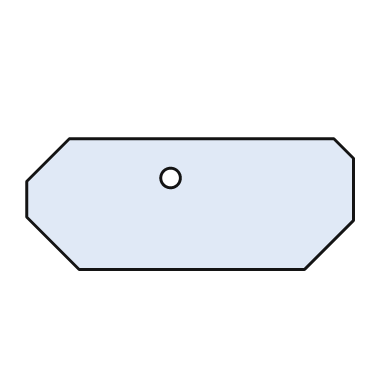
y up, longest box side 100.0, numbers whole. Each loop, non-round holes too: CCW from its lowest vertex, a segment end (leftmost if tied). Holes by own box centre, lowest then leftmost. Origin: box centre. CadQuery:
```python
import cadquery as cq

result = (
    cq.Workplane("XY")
    .moveTo(-34.0, -20.0)
    .lineTo(35.0, -20.0)
    .lineTo(50.0, -5.0)
    .lineTo(50.0, 14.0)
    .lineTo(44.0, 20.0)
    .lineTo(-37.0, 20.0)
    .lineTo(-50.0, 7.0)
    .lineTo(-50.0, -4.0)
    .close()
    .moveTo(-6.0, 8.0)
    .circle(3.0)
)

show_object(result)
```